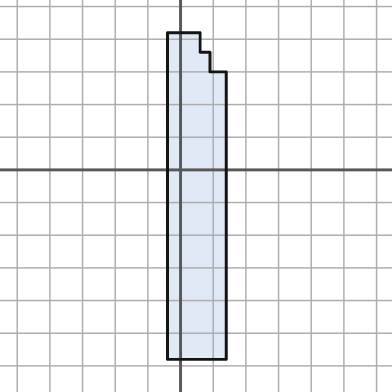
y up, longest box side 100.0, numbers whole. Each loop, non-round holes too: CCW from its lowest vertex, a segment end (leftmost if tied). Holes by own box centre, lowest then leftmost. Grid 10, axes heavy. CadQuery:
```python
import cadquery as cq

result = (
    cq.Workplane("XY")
    .moveTo(-4.0, -58.0)
    .lineTo(14.0, -58.0)
    .lineTo(14.0, 30.0)
    .lineTo(9.0, 30.0)
    .lineTo(9.0, 36.0)
    .lineTo(6.0, 36.0)
    .lineTo(6.0, 42.0)
    .lineTo(-4.0, 42.0)
    .close()
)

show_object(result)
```